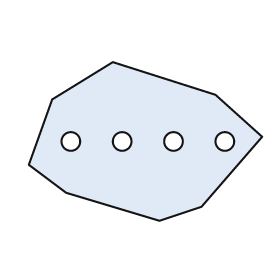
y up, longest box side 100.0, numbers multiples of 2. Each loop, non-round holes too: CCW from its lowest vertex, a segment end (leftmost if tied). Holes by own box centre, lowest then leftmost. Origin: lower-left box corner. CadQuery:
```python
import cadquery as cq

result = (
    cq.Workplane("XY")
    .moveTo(56.0, 0.0)
    .lineTo(74.0, 6.0)
    .lineTo(100.0, 36.0)
    .lineTo(80.0, 54.0)
    .lineTo(36.0, 68.0)
    .lineTo(10.0, 52.0)
    .lineTo(0.0, 24.0)
    .lineTo(16.0, 12.0)
    .close()
    .moveTo(18.0, 34.0)
    .circle(4.0)
    .moveTo(40.0, 34.0)
    .circle(4.0)
    .moveTo(62.0, 34.0)
    .circle(4.0)
    .moveTo(84.0, 34.0)
    .circle(4.0)
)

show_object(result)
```